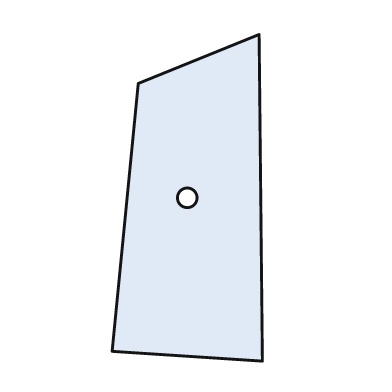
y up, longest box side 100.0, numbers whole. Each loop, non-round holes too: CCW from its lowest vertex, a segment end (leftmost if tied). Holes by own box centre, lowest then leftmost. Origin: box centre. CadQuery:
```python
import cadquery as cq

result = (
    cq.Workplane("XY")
    .moveTo(23.0, -50.0)
    .lineTo(22.0, 50.0)
    .lineTo(-15.0, 35.0)
    .lineTo(-23.0, -47.0)
    .close()
    .moveTo(0.0, 0.0)
    .circle(3.0)
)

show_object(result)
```